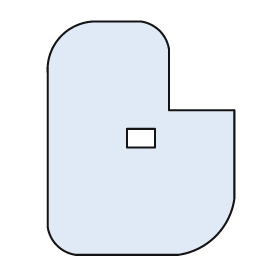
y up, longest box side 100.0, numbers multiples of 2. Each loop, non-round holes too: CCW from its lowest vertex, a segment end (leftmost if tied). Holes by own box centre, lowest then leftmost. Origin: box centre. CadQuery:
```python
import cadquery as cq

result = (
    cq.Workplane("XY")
    .moveTo(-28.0, -50.0)
    .lineTo(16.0, -50.0)
    .threePointArc((32.0, -42.0), (40.0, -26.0))
    .lineTo(40.0, 12.0)
    .lineTo(12.0, 12.0)
    .lineTo(12.0, 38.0)
    .threePointArc((8.0, 46.0), (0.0, 50.0))
    .lineTo(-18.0, 50.0)
    .threePointArc((-34.0, 44.0), (-40.0, 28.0))
    .lineTo(-40.0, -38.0)
    .threePointArc((-36.0, -46.0), (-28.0, -50.0))
    .close()
    .moveTo(-6.0, -4.0)
    .lineTo(6.0, -4.0)
    .lineTo(6.0, 4.0)
    .lineTo(-6.0, 4.0)
    .close()
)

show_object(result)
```